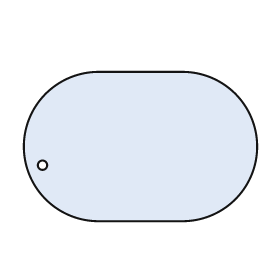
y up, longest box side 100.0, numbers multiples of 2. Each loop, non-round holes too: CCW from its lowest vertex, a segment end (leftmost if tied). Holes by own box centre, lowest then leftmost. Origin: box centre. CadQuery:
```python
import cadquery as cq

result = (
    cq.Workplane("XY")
    .moveTo(-18.0, -32.0)
    .lineTo(18.0, -32.0)
    .threePointArc((50.0, 0.0), (18.0, 32.0))
    .lineTo(-18.0, 32.0)
    .threePointArc((-50.0, 0.0), (-18.0, -32.0))
    .close()
    .moveTo(-42.0, -8.0)
    .circle(2.0)
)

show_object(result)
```